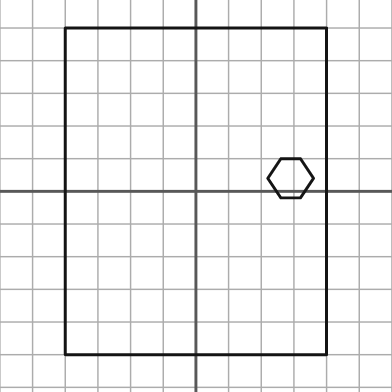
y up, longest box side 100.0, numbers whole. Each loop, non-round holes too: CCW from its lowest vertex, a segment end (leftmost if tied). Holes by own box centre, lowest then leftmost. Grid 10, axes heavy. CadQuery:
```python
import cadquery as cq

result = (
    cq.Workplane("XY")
    .moveTo(-40.0, -50.0)
    .lineTo(40.0, -50.0)
    .lineTo(40.0, 50.0)
    .lineTo(-40.0, 50.0)
    .close()
    .moveTo(26.0, -2.0)
    .lineTo(32.0, -2.0)
    .lineTo(36.0, 4.0)
    .lineTo(32.0, 10.0)
    .lineTo(26.0, 10.0)
    .lineTo(22.0, 4.0)
    .close()
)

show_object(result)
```